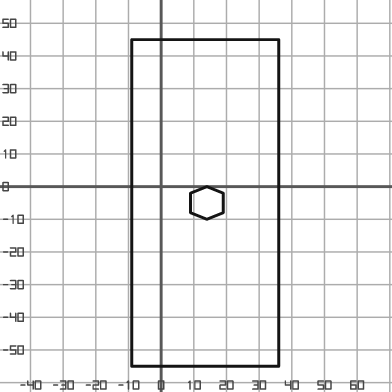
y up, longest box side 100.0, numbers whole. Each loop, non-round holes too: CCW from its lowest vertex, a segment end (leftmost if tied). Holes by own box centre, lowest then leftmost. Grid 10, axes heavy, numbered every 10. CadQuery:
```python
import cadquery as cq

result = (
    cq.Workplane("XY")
    .moveTo(-9.0, -55.0)
    .lineTo(36.0, -55.0)
    .lineTo(36.0, 45.0)
    .lineTo(-9.0, 45.0)
    .close()
    .moveTo(14.0, -10.0)
    .lineTo(19.0, -8.0)
    .lineTo(19.0, -2.0)
    .lineTo(14.0, 0.0)
    .lineTo(9.0, -2.0)
    .lineTo(9.0, -8.0)
    .close()
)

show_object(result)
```